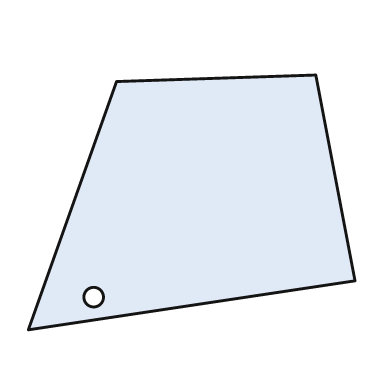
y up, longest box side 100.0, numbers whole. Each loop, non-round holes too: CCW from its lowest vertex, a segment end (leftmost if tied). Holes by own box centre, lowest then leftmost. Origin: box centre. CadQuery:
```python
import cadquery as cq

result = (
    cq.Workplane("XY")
    .moveTo(-50.0, -39.0)
    .lineTo(50.0, -24.0)
    .lineTo(38.0, 39.0)
    .lineTo(-23.0, 37.0)
    .close()
    .moveTo(-30.0, -29.0)
    .circle(3.0)
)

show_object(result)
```